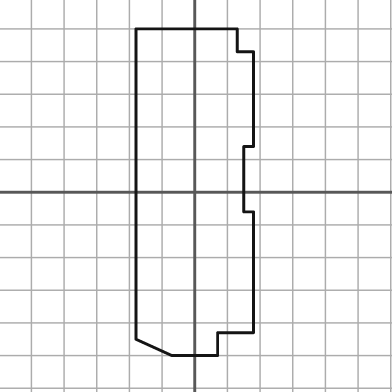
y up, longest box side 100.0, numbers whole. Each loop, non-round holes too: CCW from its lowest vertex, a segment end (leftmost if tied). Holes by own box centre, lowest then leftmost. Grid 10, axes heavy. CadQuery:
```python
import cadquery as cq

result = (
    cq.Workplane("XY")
    .moveTo(-7.0, -50.0)
    .lineTo(7.0, -50.0)
    .lineTo(7.0, -43.0)
    .lineTo(18.0, -43.0)
    .lineTo(18.0, -6.0)
    .lineTo(15.0, -6.0)
    .lineTo(15.0, 14.0)
    .lineTo(18.0, 14.0)
    .lineTo(18.0, 43.0)
    .lineTo(13.0, 43.0)
    .lineTo(13.0, 50.0)
    .lineTo(-18.0, 50.0)
    .lineTo(-18.0, -45.0)
    .close()
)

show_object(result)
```